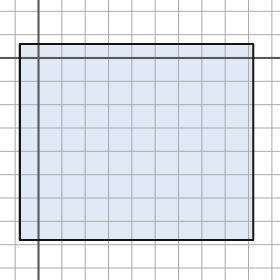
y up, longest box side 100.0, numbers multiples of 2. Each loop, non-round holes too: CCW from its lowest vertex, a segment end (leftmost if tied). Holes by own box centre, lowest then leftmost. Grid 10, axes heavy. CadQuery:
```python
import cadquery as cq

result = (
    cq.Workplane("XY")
    .moveTo(-8.0, -78.0)
    .lineTo(92.0, -78.0)
    .lineTo(92.0, 6.0)
    .lineTo(-8.0, 6.0)
    .close()
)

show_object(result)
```